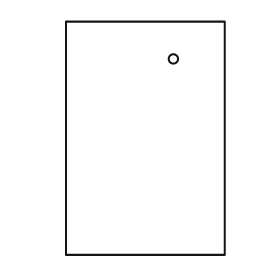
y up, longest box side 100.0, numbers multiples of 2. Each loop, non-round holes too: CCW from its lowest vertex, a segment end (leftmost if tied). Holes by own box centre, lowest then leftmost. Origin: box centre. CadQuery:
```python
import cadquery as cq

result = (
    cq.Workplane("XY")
    .moveTo(-34.0, -50.0)
    .lineTo(34.0, -50.0)
    .lineTo(34.0, 50.0)
    .lineTo(-34.0, 50.0)
    .close()
    .moveTo(12.0, 34.0)
    .circle(2.0)
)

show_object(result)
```